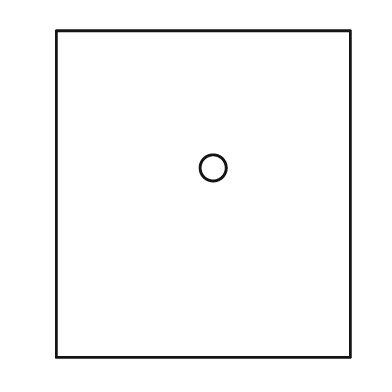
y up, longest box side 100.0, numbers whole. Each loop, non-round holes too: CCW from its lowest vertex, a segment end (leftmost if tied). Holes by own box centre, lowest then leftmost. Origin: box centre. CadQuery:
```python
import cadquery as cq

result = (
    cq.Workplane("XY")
    .moveTo(-45.0, -50.0)
    .lineTo(45.0, -50.0)
    .lineTo(45.0, 50.0)
    .lineTo(-45.0, 50.0)
    .close()
    .moveTo(3.0, 8.0)
    .circle(4.0)
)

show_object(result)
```